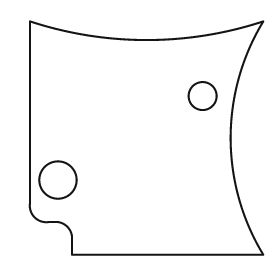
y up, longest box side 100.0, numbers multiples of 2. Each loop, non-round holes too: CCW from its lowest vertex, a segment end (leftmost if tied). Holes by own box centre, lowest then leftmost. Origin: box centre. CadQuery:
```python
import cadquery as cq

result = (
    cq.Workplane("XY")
    .moveTo(-32.0, -50.0)
    .lineTo(50.0, -50.0)
    .threePointArc((36.0, 0.0), (50.0, 50.0))
    .threePointArc((0.0, 42.0), (-50.0, 50.0))
    .lineTo(-50.0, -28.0)
    .threePointArc((-48.0, -34.0), (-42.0, -36.0))
    .lineTo(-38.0, -36.0)
    .threePointArc((-34.0, -38.0), (-32.0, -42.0))
    .close()
    .moveTo(-38.0, -18.0)
    .circle(8.0)
    .moveTo(24.0, 18.0)
    .circle(6.0)
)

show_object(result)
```